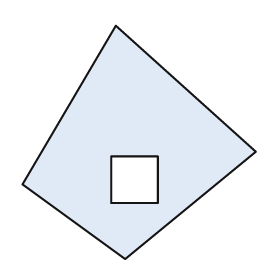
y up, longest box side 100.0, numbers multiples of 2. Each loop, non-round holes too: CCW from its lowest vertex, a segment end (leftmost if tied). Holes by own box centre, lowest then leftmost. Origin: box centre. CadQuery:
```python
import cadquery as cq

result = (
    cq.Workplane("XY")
    .moveTo(-6.0, -50.0)
    .lineTo(50.0, -4.0)
    .lineTo(-10.0, 50.0)
    .lineTo(-50.0, -18.0)
    .close()
    .moveTo(-12.0, -26.0)
    .lineTo(8.0, -26.0)
    .lineTo(8.0, -6.0)
    .lineTo(-12.0, -6.0)
    .close()
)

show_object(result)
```